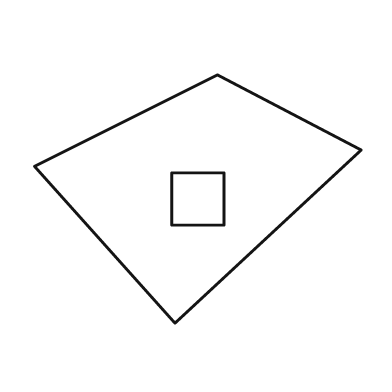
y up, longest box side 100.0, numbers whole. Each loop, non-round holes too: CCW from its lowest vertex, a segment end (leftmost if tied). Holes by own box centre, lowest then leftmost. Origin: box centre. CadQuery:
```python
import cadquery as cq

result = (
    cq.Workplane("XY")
    .moveTo(-7.0, -38.0)
    .lineTo(50.0, 15.0)
    .lineTo(6.0, 38.0)
    .lineTo(-50.0, 10.0)
    .close()
    .moveTo(-8.0, -8.0)
    .lineTo(8.0, -8.0)
    .lineTo(8.0, 8.0)
    .lineTo(-8.0, 8.0)
    .close()
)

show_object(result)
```